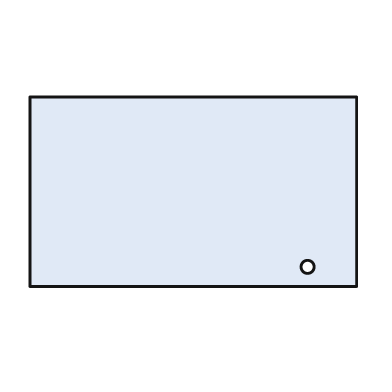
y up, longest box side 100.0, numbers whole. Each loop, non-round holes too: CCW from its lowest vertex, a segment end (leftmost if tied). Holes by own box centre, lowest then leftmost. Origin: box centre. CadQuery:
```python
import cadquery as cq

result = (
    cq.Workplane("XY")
    .moveTo(-50.0, -29.0)
    .lineTo(50.0, -29.0)
    .lineTo(50.0, 29.0)
    .lineTo(-50.0, 29.0)
    .close()
    .moveTo(35.0, -23.0)
    .circle(2.0)
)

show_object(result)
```